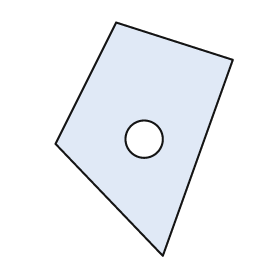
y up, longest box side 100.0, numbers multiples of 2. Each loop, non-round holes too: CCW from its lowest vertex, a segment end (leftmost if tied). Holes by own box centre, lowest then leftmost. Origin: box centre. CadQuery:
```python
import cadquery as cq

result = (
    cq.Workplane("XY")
    .moveTo(8.0, -50.0)
    .lineTo(38.0, 34.0)
    .lineTo(-12.0, 50.0)
    .lineTo(-38.0, -2.0)
    .close()
    .moveTo(0.0, 0.0)
    .circle(8.0)
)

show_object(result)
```